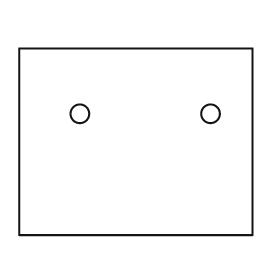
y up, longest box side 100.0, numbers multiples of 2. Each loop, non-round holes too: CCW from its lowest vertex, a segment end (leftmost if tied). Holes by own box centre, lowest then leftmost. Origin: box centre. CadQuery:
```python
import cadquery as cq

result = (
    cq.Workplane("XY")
    .moveTo(-50.0, -40.0)
    .lineTo(50.0, -40.0)
    .lineTo(50.0, 40.0)
    .lineTo(-50.0, 40.0)
    .close()
    .moveTo(-24.0, 12.0)
    .circle(4.0)
    .moveTo(32.0, 12.0)
    .circle(4.0)
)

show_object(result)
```